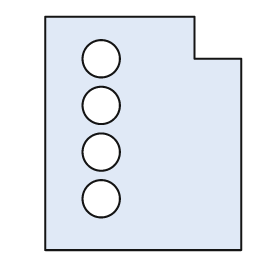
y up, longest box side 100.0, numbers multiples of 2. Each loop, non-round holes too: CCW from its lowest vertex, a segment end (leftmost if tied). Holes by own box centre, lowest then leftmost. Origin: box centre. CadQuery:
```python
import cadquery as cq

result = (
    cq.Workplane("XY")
    .moveTo(-42.0, -50.0)
    .lineTo(42.0, -50.0)
    .lineTo(42.0, 32.0)
    .lineTo(22.0, 32.0)
    .lineTo(22.0, 50.0)
    .lineTo(-42.0, 50.0)
    .close()
    .moveTo(-18.0, -28.0)
    .circle(8.0)
    .moveTo(-18.0, -8.0)
    .circle(8.0)
    .moveTo(-18.0, 12.0)
    .circle(8.0)
    .moveTo(-18.0, 32.0)
    .circle(8.0)
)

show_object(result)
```